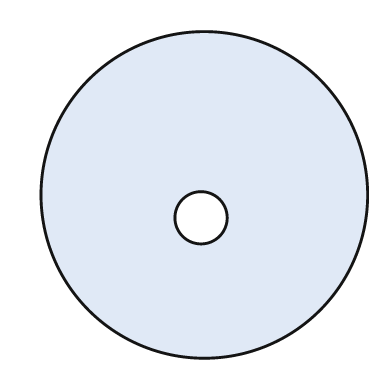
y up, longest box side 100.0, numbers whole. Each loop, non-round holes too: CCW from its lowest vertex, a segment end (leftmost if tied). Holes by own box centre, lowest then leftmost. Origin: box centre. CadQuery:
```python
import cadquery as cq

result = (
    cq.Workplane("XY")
    .moveTo(0.0, 0.0)
    .circle(50.0)
    .moveTo(-1.0, -7.0)
    .circle(8.0)
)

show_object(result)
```